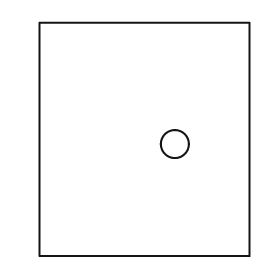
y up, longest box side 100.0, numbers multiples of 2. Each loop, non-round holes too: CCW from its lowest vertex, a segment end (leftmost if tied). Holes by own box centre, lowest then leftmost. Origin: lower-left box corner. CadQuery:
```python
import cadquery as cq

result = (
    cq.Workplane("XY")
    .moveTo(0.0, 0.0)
    .lineTo(90.0, 0.0)
    .lineTo(90.0, 100.0)
    .lineTo(0.0, 100.0)
    .close()
    .moveTo(58.0, 48.0)
    .circle(6.0)
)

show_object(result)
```